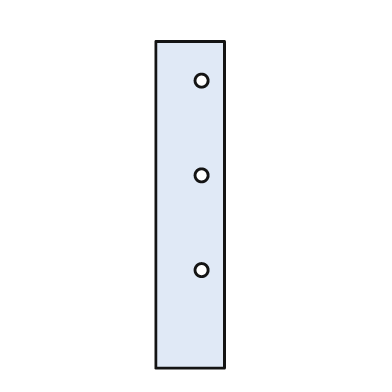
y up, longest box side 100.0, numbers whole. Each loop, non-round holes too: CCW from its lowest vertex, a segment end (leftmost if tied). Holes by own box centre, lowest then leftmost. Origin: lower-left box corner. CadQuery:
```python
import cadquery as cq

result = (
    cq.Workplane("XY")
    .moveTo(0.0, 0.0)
    .lineTo(21.0, 0.0)
    .lineTo(21.0, 100.0)
    .lineTo(0.0, 100.0)
    .close()
    .moveTo(14.0, 30.0)
    .circle(2.0)
    .moveTo(14.0, 59.0)
    .circle(2.0)
    .moveTo(14.0, 88.0)
    .circle(2.0)
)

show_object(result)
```